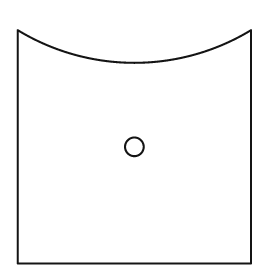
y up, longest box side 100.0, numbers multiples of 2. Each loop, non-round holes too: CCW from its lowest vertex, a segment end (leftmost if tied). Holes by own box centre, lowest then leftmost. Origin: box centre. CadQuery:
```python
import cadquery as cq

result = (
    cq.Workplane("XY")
    .moveTo(-50.0, -50.0)
    .lineTo(50.0, -50.0)
    .lineTo(50.0, 50.0)
    .threePointArc((0.0, 36.0), (-50.0, 50.0))
    .close()
    .moveTo(0.0, 0.0)
    .circle(4.0)
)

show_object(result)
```